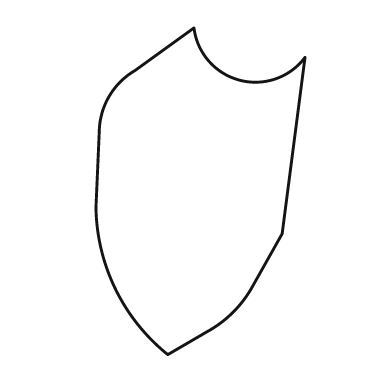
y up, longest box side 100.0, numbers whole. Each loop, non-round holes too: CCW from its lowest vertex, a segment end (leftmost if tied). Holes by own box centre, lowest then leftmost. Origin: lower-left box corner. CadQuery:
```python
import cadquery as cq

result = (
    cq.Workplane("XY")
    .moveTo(22.0, 0.0)
    .lineTo(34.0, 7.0)
    .threePointArc((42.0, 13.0), (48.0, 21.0))
    .lineTo(57.0, 37.0)
    .lineTo(64.0, 91.0)
    .threePointArc((44.0, 84.0), (30.0, 100.0))
    .lineTo(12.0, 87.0)
    .threePointArc((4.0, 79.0), (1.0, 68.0))
    .lineTo(0.0, 45.0)
    .threePointArc((6.0, 20.0), (22.0, 0.0))
    .close()
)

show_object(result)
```